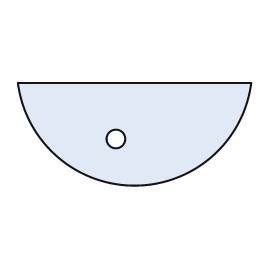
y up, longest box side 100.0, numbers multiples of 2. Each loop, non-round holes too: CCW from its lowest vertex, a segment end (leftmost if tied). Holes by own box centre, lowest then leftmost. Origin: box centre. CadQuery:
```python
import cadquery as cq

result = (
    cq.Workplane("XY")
    .moveTo(-50.0, 22.0)
    .threePointArc((0.0, -22.0), (50.0, 22.0))
    .close()
    .moveTo(-8.0, -2.0)
    .circle(4.0)
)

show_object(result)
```